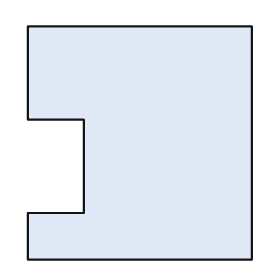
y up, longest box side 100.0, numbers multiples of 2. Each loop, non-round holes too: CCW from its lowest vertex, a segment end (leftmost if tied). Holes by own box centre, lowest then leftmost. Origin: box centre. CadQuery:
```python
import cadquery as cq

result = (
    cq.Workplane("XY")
    .moveTo(-48.0, -50.0)
    .lineTo(48.0, -50.0)
    .lineTo(48.0, 50.0)
    .lineTo(-48.0, 50.0)
    .lineTo(-48.0, 10.0)
    .lineTo(-24.0, 10.0)
    .lineTo(-24.0, -30.0)
    .lineTo(-48.0, -30.0)
    .close()
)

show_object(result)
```